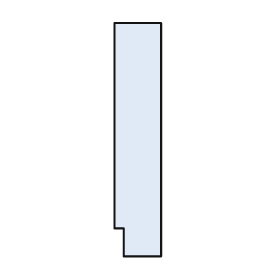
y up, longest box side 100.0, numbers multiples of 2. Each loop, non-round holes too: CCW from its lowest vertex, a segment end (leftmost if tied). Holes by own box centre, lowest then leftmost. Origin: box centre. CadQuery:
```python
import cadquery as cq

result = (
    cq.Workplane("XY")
    .moveTo(-6.0, -50.0)
    .lineTo(10.0, -50.0)
    .lineTo(10.0, 50.0)
    .lineTo(-10.0, 50.0)
    .lineTo(-10.0, -38.0)
    .lineTo(-6.0, -38.0)
    .close()
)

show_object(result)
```